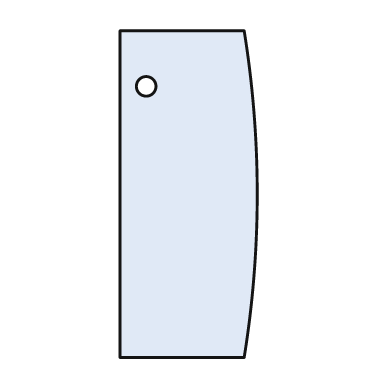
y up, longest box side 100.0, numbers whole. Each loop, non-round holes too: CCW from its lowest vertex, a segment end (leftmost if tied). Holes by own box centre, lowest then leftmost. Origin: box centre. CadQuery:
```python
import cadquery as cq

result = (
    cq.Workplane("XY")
    .moveTo(-21.0, -50.0)
    .lineTo(17.0, -50.0)
    .threePointArc((21.0, 0.0), (17.0, 50.0))
    .lineTo(-21.0, 50.0)
    .close()
    .moveTo(-13.0, 33.0)
    .circle(3.0)
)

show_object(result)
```